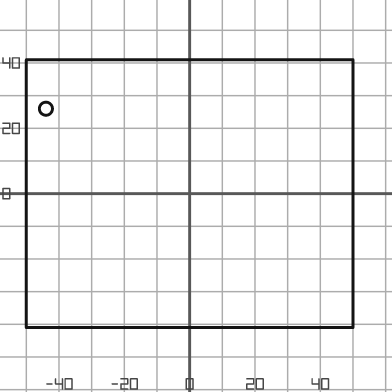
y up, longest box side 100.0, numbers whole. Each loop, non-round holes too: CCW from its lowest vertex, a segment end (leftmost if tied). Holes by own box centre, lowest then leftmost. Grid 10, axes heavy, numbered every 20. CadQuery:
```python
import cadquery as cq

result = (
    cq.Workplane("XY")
    .moveTo(-50.0, -41.0)
    .lineTo(50.0, -41.0)
    .lineTo(50.0, 41.0)
    .lineTo(-50.0, 41.0)
    .close()
    .moveTo(-44.0, 26.0)
    .circle(2.0)
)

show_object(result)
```